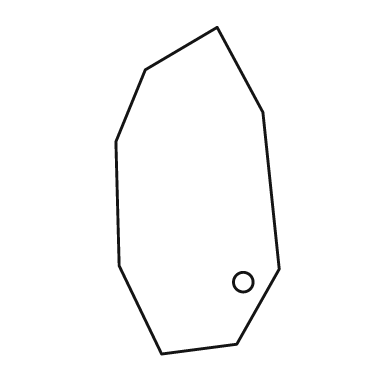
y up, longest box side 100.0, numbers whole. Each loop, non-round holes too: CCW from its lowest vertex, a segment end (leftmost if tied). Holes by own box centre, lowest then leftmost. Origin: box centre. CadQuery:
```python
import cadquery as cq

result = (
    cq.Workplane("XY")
    .moveTo(-11.0, -50.0)
    .lineTo(12.0, -47.0)
    .lineTo(25.0, -24.0)
    .lineTo(20.0, 24.0)
    .lineTo(6.0, 50.0)
    .lineTo(-16.0, 37.0)
    .lineTo(-25.0, 15.0)
    .lineTo(-24.0, -23.0)
    .close()
    .moveTo(14.0, -28.0)
    .circle(3.0)
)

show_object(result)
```